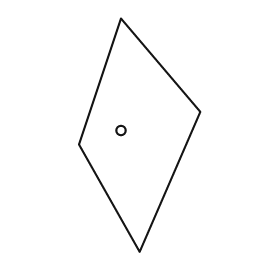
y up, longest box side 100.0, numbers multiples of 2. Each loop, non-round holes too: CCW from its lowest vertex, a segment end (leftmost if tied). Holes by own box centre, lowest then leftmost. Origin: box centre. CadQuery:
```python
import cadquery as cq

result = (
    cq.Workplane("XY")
    .moveTo(0.0, -50.0)
    .lineTo(26.0, 10.0)
    .lineTo(-8.0, 50.0)
    .lineTo(-26.0, -4.0)
    .close()
    .moveTo(-8.0, 2.0)
    .circle(2.0)
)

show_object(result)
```